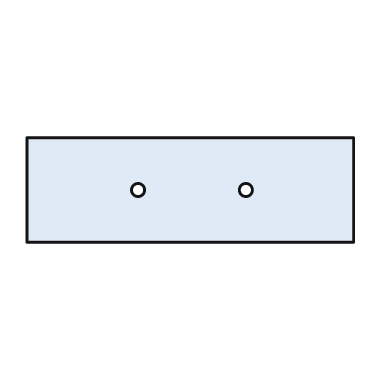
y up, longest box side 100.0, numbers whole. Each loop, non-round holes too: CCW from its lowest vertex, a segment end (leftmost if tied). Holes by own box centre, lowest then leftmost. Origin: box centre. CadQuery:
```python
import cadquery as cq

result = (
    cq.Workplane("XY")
    .moveTo(-50.0, -16.0)
    .lineTo(50.0, -16.0)
    .lineTo(50.0, 16.0)
    .lineTo(-50.0, 16.0)
    .close()
    .moveTo(-16.0, 0.0)
    .circle(2.0)
    .moveTo(17.0, 0.0)
    .circle(2.0)
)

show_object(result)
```